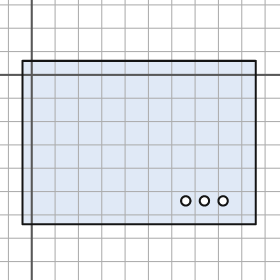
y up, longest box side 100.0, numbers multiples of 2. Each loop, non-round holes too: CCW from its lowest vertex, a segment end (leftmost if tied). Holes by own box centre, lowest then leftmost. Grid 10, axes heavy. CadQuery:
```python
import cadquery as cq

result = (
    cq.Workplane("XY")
    .moveTo(-4.0, -64.0)
    .lineTo(96.0, -64.0)
    .lineTo(96.0, 6.0)
    .lineTo(-4.0, 6.0)
    .close()
    .moveTo(66.0, -54.0)
    .circle(2.0)
    .moveTo(74.0, -54.0)
    .circle(2.0)
    .moveTo(82.0, -54.0)
    .circle(2.0)
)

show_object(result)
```